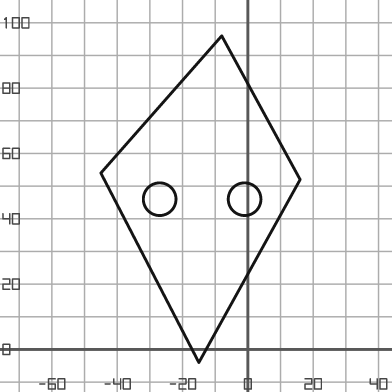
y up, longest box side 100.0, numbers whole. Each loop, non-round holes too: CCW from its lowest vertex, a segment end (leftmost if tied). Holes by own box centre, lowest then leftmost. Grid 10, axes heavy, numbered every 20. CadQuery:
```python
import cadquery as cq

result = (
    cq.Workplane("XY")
    .moveTo(-15.0, -4.0)
    .lineTo(16.0, 52.0)
    .lineTo(-8.0, 96.0)
    .lineTo(-45.0, 54.0)
    .close()
    .moveTo(-27.0, 46.0)
    .circle(5.0)
    .moveTo(-1.0, 46.0)
    .circle(5.0)
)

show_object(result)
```